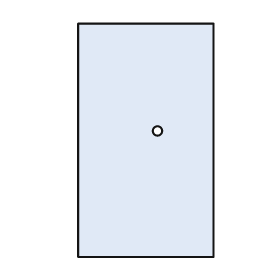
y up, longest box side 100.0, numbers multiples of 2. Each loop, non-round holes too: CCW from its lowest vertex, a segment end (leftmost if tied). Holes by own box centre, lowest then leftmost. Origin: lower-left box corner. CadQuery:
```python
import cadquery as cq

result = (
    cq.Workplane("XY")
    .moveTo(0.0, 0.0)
    .lineTo(58.0, 0.0)
    .lineTo(58.0, 100.0)
    .lineTo(0.0, 100.0)
    .close()
    .moveTo(34.0, 54.0)
    .circle(2.0)
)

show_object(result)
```